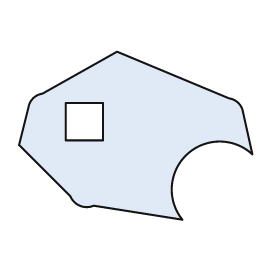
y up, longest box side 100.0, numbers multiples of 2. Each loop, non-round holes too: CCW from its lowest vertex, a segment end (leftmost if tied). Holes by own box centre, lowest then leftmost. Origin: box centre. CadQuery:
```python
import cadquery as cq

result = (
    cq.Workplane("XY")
    .moveTo(20.0, -36.0)
    .threePointArc((22.0, -8.0), (50.0, -8.0))
    .lineTo(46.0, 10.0)
    .threePointArc((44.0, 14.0), (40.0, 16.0))
    .lineTo(-8.0, 36.0)
    .lineTo(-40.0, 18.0)
    .threePointArc((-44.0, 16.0), (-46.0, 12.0))
    .lineTo(-50.0, -4.0)
    .lineTo(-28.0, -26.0)
    .threePointArc((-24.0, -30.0), (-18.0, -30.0))
    .close()
    .moveTo(-30.0, -2.0)
    .lineTo(-14.0, -2.0)
    .lineTo(-14.0, 14.0)
    .lineTo(-30.0, 14.0)
    .close()
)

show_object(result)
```